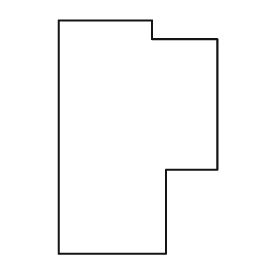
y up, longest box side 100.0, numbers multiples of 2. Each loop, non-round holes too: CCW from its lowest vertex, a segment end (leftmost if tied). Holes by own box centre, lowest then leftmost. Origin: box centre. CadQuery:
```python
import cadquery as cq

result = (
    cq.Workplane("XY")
    .moveTo(-34.0, -50.0)
    .lineTo(12.0, -50.0)
    .lineTo(12.0, -14.0)
    .lineTo(34.0, -14.0)
    .lineTo(34.0, 42.0)
    .lineTo(6.0, 42.0)
    .lineTo(6.0, 50.0)
    .lineTo(-34.0, 50.0)
    .close()
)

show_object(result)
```